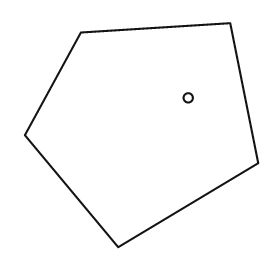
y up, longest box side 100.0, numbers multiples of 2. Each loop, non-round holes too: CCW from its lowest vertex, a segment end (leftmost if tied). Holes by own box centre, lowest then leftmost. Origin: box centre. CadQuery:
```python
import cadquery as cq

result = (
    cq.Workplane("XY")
    .moveTo(-10.0, -48.0)
    .lineTo(50.0, -12.0)
    .lineTo(38.0, 48.0)
    .lineTo(-26.0, 44.0)
    .lineTo(-50.0, 0.0)
    .close()
    .moveTo(20.0, 16.0)
    .circle(2.0)
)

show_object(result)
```